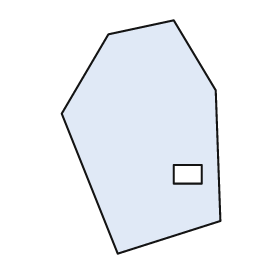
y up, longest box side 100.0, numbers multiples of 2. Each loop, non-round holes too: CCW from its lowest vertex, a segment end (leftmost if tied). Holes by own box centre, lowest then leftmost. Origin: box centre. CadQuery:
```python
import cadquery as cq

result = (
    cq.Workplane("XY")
    .moveTo(-10.0, -50.0)
    .lineTo(34.0, -36.0)
    .lineTo(32.0, 20.0)
    .lineTo(14.0, 50.0)
    .lineTo(-14.0, 44.0)
    .lineTo(-34.0, 10.0)
    .close()
    .moveTo(14.0, -20.0)
    .lineTo(26.0, -20.0)
    .lineTo(26.0, -12.0)
    .lineTo(14.0, -12.0)
    .close()
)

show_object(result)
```